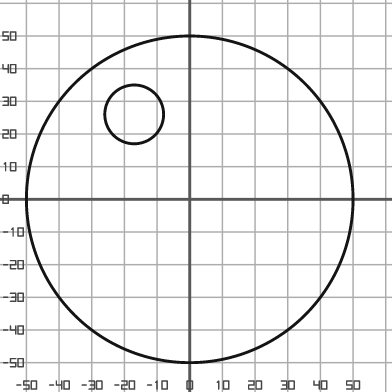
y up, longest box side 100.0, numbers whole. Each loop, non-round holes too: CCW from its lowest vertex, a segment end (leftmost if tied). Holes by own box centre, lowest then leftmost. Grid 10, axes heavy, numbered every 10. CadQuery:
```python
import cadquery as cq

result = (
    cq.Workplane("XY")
    .moveTo(0.0, 0.0)
    .circle(50.0)
    .moveTo(-17.0, 26.0)
    .circle(9.0)
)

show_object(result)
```